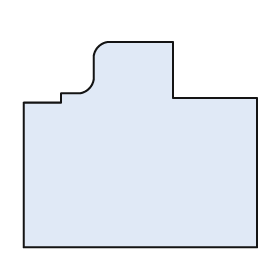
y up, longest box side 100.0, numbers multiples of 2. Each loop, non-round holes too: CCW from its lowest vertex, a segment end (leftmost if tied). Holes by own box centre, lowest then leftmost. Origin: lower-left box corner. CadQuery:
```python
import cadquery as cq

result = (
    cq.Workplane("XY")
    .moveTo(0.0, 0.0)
    .lineTo(100.0, 0.0)
    .lineTo(100.0, 64.0)
    .lineTo(64.0, 64.0)
    .lineTo(64.0, 88.0)
    .lineTo(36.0, 88.0)
    .threePointArc((32.0, 86.0), (30.0, 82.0))
    .lineTo(30.0, 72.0)
    .threePointArc((28.0, 68.0), (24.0, 66.0))
    .lineTo(16.0, 66.0)
    .lineTo(16.0, 62.0)
    .lineTo(0.0, 62.0)
    .close()
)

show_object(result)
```